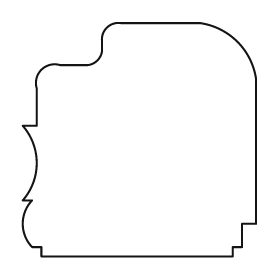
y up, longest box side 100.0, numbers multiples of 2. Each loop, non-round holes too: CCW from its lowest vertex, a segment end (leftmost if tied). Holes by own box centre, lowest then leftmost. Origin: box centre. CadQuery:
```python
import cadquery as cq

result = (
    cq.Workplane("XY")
    .moveTo(-42.0, -50.0)
    .lineTo(40.0, -50.0)
    .lineTo(40.0, -46.0)
    .lineTo(44.0, -46.0)
    .lineTo(44.0, -36.0)
    .lineTo(50.0, -36.0)
    .lineTo(50.0, 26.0)
    .threePointArc((42.0, 42.0), (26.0, 50.0))
    .lineTo(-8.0, 50.0)
    .threePointArc((-14.0, 48.0), (-16.0, 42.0))
    .lineTo(-16.0, 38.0)
    .threePointArc((-18.0, 34.0), (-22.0, 32.0))
    .lineTo(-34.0, 32.0)
    .threePointArc((-42.0, 30.0), (-44.0, 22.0))
    .lineTo(-44.0, 6.0)
    .lineTo(-50.0, 6.0)
    .threePointArc((-44.0, -10.0), (-50.0, -26.0))
    .lineTo(-46.0, -26.0)
    .threePointArc((-50.0, -36.0), (-46.0, -46.0))
    .lineTo(-42.0, -46.0)
    .close()
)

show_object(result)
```